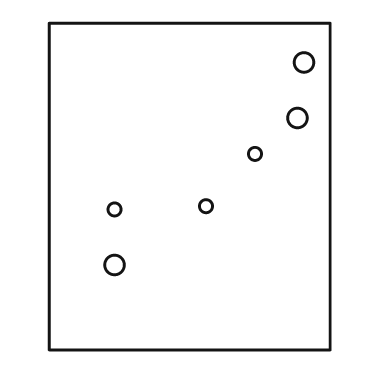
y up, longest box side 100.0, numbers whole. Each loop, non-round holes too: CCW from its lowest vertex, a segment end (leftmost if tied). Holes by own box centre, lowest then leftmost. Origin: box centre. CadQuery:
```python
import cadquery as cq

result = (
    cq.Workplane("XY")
    .moveTo(-43.0, -50.0)
    .lineTo(43.0, -50.0)
    .lineTo(43.0, 50.0)
    .lineTo(-43.0, 50.0)
    .close()
    .moveTo(-23.0, -24.0)
    .circle(3.0)
    .moveTo(-23.0, -7.0)
    .circle(2.0)
    .moveTo(5.0, -6.0)
    .circle(2.0)
    .moveTo(20.0, 10.0)
    .circle(2.0)
    .moveTo(33.0, 21.0)
    .circle(3.0)
    .moveTo(35.0, 38.0)
    .circle(3.0)
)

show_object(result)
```